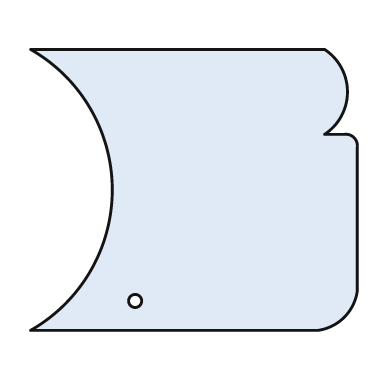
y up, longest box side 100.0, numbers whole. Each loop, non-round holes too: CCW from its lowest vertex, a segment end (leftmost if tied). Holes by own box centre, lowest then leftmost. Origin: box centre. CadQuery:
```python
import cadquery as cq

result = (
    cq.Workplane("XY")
    .moveTo(-50.0, -43.0)
    .lineTo(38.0, -43.0)
    .threePointArc((46.0, -39.0), (50.0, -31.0))
    .lineTo(50.0, 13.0)
    .threePointArc((49.0, 16.0), (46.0, 17.0))
    .lineTo(40.0, 17.0)
    .threePointArc((47.0, 30.0), (40.0, 43.0))
    .lineTo(-50.0, 43.0)
    .threePointArc((-25.0, 0.0), (-50.0, -43.0))
    .close()
    .moveTo(-18.0, -34.0)
    .circle(2.0)
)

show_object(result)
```